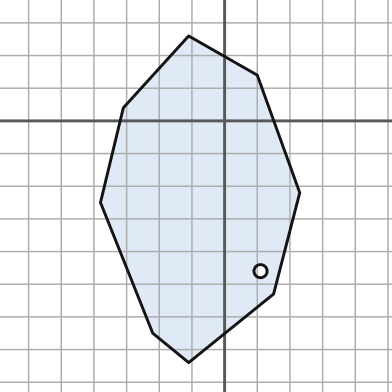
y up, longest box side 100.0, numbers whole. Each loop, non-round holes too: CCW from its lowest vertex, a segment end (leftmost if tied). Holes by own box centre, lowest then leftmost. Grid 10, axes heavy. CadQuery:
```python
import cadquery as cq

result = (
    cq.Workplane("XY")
    .moveTo(-11.0, -74.0)
    .lineTo(15.0, -53.0)
    .lineTo(23.0, -22.0)
    .lineTo(10.0, 14.0)
    .lineTo(-11.0, 26.0)
    .lineTo(-31.0, 4.0)
    .lineTo(-38.0, -25.0)
    .lineTo(-22.0, -65.0)
    .close()
    .moveTo(11.0, -46.0)
    .circle(2.0)
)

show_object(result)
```